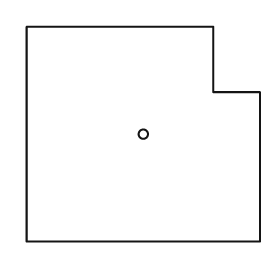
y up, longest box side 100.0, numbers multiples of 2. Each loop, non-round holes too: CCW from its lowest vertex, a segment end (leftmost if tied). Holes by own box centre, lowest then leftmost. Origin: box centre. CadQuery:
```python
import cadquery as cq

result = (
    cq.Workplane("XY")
    .moveTo(-50.0, -46.0)
    .lineTo(50.0, -46.0)
    .lineTo(50.0, 18.0)
    .lineTo(30.0, 18.0)
    .lineTo(30.0, 46.0)
    .lineTo(-50.0, 46.0)
    .close()
    .moveTo(0.0, 0.0)
    .circle(2.0)
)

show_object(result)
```